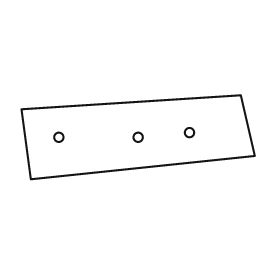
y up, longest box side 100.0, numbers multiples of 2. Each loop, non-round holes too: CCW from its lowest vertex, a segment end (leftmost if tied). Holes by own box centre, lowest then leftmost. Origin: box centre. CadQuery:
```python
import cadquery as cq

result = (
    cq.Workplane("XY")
    .moveTo(-46.0, -18.0)
    .lineTo(50.0, -8.0)
    .lineTo(44.0, 18.0)
    .lineTo(-50.0, 12.0)
    .close()
    .moveTo(-34.0, 0.0)
    .circle(2.0)
    .moveTo(0.0, 0.0)
    .circle(2.0)
    .moveTo(22.0, 2.0)
    .circle(2.0)
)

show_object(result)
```